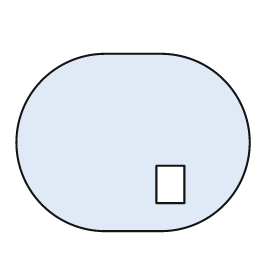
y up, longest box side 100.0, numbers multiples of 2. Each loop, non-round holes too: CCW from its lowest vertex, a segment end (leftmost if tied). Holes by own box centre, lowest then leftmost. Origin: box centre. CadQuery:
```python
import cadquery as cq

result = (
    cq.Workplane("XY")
    .moveTo(-12.0, -38.0)
    .lineTo(12.0, -38.0)
    .threePointArc((50.0, 0.0), (12.0, 38.0))
    .lineTo(-12.0, 38.0)
    .threePointArc((-50.0, 0.0), (-12.0, -38.0))
    .close()
    .moveTo(10.0, -26.0)
    .lineTo(22.0, -26.0)
    .lineTo(22.0, -10.0)
    .lineTo(10.0, -10.0)
    .close()
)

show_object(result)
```